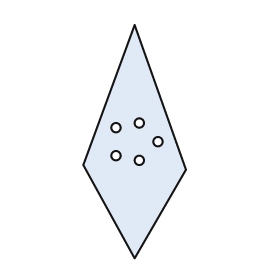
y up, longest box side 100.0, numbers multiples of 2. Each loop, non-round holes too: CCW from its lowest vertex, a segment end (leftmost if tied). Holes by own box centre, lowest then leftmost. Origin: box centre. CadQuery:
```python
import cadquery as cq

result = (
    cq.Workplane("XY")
    .moveTo(0.0, -50.0)
    .lineTo(22.0, -12.0)
    .lineTo(0.0, 50.0)
    .lineTo(-22.0, -10.0)
    .close()
    .moveTo(2.0, -8.0)
    .circle(2.0)
    .moveTo(-8.0, -6.0)
    .circle(2.0)
    .moveTo(10.0, 0.0)
    .circle(2.0)
    .moveTo(-8.0, 6.0)
    .circle(2.0)
    .moveTo(2.0, 8.0)
    .circle(2.0)
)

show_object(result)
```